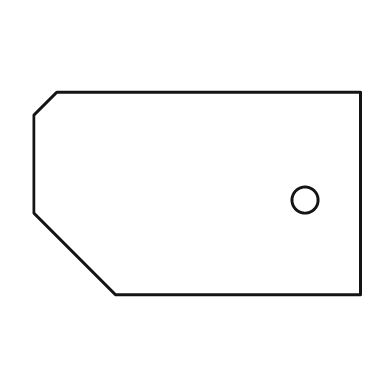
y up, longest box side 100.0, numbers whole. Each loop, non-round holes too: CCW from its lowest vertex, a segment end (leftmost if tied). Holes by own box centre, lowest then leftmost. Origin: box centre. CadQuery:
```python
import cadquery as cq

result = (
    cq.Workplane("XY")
    .moveTo(-25.0, -31.0)
    .lineTo(50.0, -31.0)
    .lineTo(50.0, 31.0)
    .lineTo(-43.0, 31.0)
    .lineTo(-50.0, 24.0)
    .lineTo(-50.0, -6.0)
    .close()
    .moveTo(33.0, -2.0)
    .circle(4.0)
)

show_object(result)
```